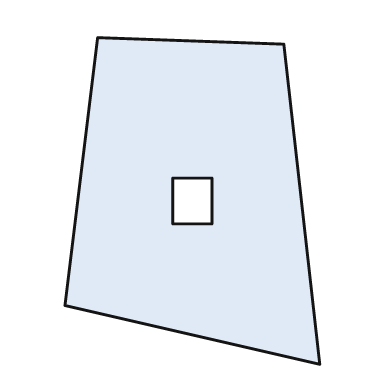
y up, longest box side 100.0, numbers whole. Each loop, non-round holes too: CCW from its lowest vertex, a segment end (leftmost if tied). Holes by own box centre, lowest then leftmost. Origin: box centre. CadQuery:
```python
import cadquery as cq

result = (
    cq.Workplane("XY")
    .moveTo(39.0, -50.0)
    .lineTo(28.0, 48.0)
    .lineTo(-29.0, 50.0)
    .lineTo(-39.0, -32.0)
    .close()
    .moveTo(-6.0, -7.0)
    .lineTo(6.0, -7.0)
    .lineTo(6.0, 7.0)
    .lineTo(-6.0, 7.0)
    .close()
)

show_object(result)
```